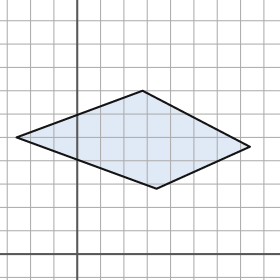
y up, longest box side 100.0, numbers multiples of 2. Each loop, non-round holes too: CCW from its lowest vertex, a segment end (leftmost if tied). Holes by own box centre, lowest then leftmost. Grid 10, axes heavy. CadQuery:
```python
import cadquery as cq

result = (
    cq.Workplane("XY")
    .moveTo(34.0, 28.0)
    .lineTo(74.0, 46.0)
    .lineTo(28.0, 70.0)
    .lineTo(-26.0, 50.0)
    .close()
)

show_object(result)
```